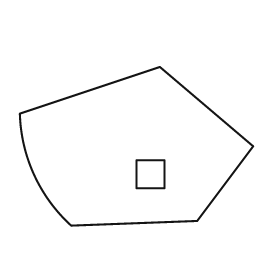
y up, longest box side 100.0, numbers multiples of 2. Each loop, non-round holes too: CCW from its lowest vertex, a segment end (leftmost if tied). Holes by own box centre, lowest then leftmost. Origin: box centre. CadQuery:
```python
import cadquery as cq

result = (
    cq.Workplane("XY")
    .moveTo(-28.0, -34.0)
    .lineTo(26.0, -32.0)
    .lineTo(50.0, 0.0)
    .lineTo(10.0, 34.0)
    .lineTo(-50.0, 14.0)
    .threePointArc((-44.0, -12.0), (-28.0, -34.0))
    .close()
    .moveTo(0.0, -18.0)
    .lineTo(12.0, -18.0)
    .lineTo(12.0, -6.0)
    .lineTo(0.0, -6.0)
    .close()
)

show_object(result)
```